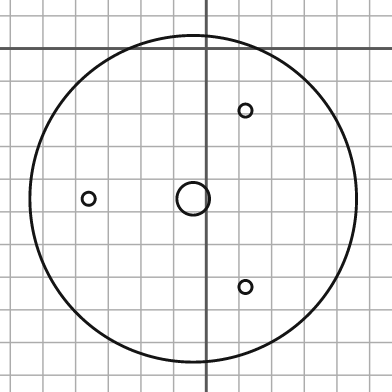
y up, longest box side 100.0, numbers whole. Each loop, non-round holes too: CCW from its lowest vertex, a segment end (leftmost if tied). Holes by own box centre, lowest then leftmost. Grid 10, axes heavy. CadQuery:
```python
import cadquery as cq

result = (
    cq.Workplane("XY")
    .moveTo(-4.0, -46.0)
    .circle(50.0)
    .moveTo(12.0, -73.0)
    .circle(2.0)
    .moveTo(-36.0, -46.0)
    .circle(2.0)
    .moveTo(-4.0, -46.0)
    .circle(5.0)
    .moveTo(12.0, -19.0)
    .circle(2.0)
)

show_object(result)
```